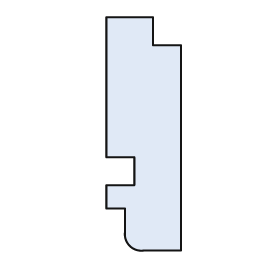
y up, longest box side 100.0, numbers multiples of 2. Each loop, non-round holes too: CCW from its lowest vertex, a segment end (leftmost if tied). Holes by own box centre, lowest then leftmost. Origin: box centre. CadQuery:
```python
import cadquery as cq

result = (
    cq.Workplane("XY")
    .moveTo(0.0, -50.0)
    .lineTo(16.0, -50.0)
    .lineTo(16.0, 38.0)
    .lineTo(4.0, 38.0)
    .lineTo(4.0, 50.0)
    .lineTo(-16.0, 50.0)
    .lineTo(-16.0, -10.0)
    .lineTo(-4.0, -10.0)
    .lineTo(-4.0, -22.0)
    .lineTo(-16.0, -22.0)
    .lineTo(-16.0, -32.0)
    .lineTo(-8.0, -32.0)
    .lineTo(-8.0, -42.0)
    .threePointArc((-6.0, -48.0), (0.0, -50.0))
    .close()
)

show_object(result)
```